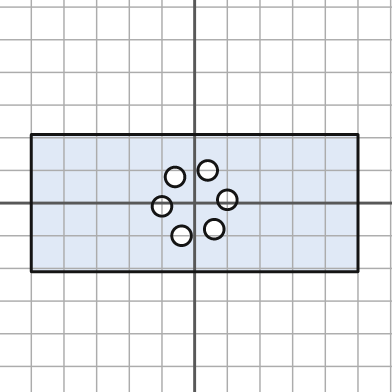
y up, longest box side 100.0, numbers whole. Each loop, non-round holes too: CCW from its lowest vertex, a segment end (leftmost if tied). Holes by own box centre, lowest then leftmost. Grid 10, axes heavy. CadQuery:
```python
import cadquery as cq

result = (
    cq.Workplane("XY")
    .moveTo(-50.0, -21.0)
    .lineTo(50.0, -21.0)
    .lineTo(50.0, 21.0)
    .lineTo(-50.0, 21.0)
    .close()
    .moveTo(-4.0, -10.0)
    .circle(3.0)
    .moveTo(6.0, -8.0)
    .circle(3.0)
    .moveTo(-10.0, -1.0)
    .circle(3.0)
    .moveTo(10.0, 1.0)
    .circle(3.0)
    .moveTo(-6.0, 8.0)
    .circle(3.0)
    .moveTo(4.0, 10.0)
    .circle(3.0)
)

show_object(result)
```